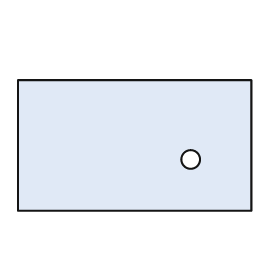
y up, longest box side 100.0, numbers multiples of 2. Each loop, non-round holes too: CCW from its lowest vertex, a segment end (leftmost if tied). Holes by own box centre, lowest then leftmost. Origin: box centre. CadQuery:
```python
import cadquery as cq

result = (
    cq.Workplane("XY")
    .moveTo(-50.0, -28.0)
    .lineTo(50.0, -28.0)
    .lineTo(50.0, 28.0)
    .lineTo(-50.0, 28.0)
    .close()
    .moveTo(24.0, -6.0)
    .circle(4.0)
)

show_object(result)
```